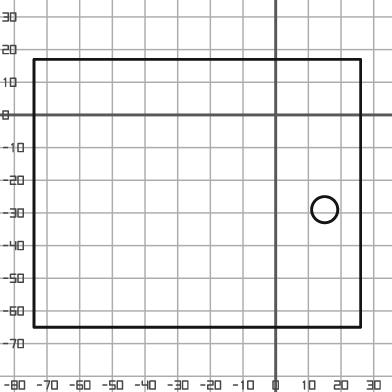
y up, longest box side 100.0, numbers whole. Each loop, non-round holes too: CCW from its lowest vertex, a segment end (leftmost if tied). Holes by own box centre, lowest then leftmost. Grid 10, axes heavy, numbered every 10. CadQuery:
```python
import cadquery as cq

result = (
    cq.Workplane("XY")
    .moveTo(-74.0, -65.0)
    .lineTo(26.0, -65.0)
    .lineTo(26.0, 17.0)
    .lineTo(-74.0, 17.0)
    .close()
    .moveTo(15.0, -29.0)
    .circle(4.0)
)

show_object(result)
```